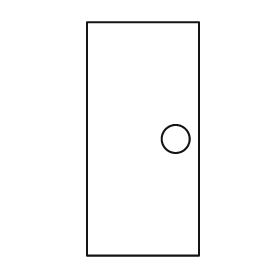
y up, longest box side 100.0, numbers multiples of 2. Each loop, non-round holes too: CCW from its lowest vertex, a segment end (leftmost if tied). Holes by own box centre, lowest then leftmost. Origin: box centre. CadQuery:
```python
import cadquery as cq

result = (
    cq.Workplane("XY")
    .moveTo(-24.0, -50.0)
    .lineTo(24.0, -50.0)
    .lineTo(24.0, 50.0)
    .lineTo(-24.0, 50.0)
    .close()
    .moveTo(14.0, 0.0)
    .circle(6.0)
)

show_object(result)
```